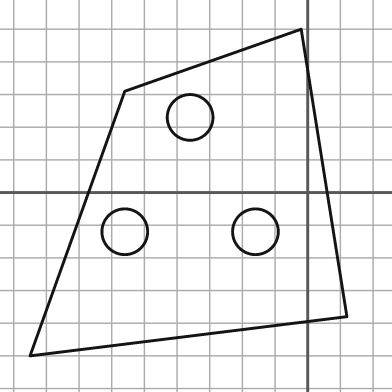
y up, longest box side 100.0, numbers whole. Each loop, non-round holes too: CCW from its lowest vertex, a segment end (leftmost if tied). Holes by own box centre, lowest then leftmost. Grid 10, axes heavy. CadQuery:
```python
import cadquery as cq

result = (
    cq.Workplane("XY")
    .moveTo(-85.0, -50.0)
    .lineTo(12.0, -38.0)
    .lineTo(-2.0, 50.0)
    .lineTo(-56.0, 31.0)
    .close()
    .moveTo(-56.0, -12.0)
    .circle(7.0)
    .moveTo(-16.0, -12.0)
    .circle(7.0)
    .moveTo(-36.0, 23.0)
    .circle(7.0)
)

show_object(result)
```